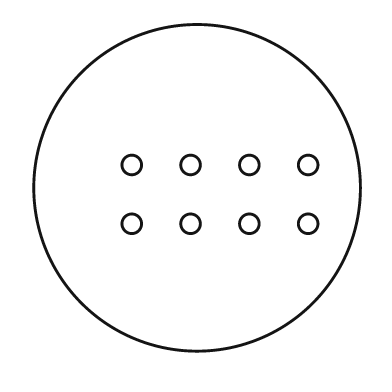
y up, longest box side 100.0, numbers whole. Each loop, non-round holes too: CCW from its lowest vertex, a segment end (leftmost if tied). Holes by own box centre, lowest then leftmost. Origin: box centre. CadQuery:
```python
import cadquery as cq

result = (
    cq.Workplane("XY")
    .moveTo(0.0, 0.0)
    .circle(50.0)
    .moveTo(-20.0, -11.0)
    .circle(3.0)
    .moveTo(-2.0, -11.0)
    .circle(3.0)
    .moveTo(16.0, -11.0)
    .circle(3.0)
    .moveTo(34.0, -11.0)
    .circle(3.0)
    .moveTo(-20.0, 7.0)
    .circle(3.0)
    .moveTo(-2.0, 7.0)
    .circle(3.0)
    .moveTo(16.0, 7.0)
    .circle(3.0)
    .moveTo(34.0, 7.0)
    .circle(3.0)
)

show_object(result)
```